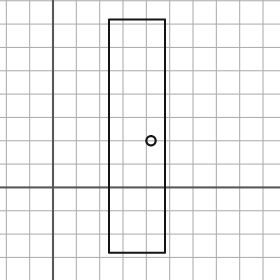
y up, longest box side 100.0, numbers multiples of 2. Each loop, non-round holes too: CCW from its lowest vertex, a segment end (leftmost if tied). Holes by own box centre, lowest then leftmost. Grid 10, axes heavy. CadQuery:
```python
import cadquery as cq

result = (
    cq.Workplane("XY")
    .moveTo(24.0, -28.0)
    .lineTo(48.0, -28.0)
    .lineTo(48.0, 72.0)
    .lineTo(24.0, 72.0)
    .close()
    .moveTo(42.0, 20.0)
    .circle(2.0)
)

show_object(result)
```